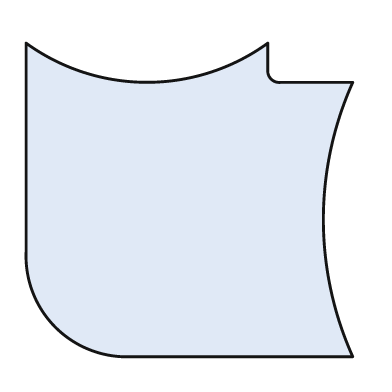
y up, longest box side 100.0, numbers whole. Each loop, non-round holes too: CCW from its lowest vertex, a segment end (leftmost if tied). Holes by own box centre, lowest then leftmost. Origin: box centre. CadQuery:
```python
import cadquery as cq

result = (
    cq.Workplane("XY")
    .moveTo(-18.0, -48.0)
    .lineTo(50.0, -48.0)
    .threePointArc((41.0, -6.0), (50.0, 36.0))
    .lineTo(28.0, 36.0)
    .threePointArc((25.0, 37.0), (24.0, 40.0))
    .lineTo(24.0, 48.0)
    .threePointArc((-13.0, 36.0), (-50.0, 48.0))
    .lineTo(-50.0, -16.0)
    .threePointArc((-41.0, -39.0), (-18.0, -48.0))
    .close()
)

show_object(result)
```